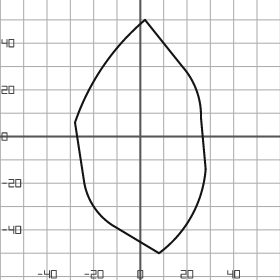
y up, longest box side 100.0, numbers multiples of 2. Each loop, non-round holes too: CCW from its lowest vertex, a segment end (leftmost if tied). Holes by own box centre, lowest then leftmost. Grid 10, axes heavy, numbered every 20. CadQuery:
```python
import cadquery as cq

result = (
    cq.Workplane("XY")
    .moveTo(8.0, -50.0)
    .threePointArc((22.0, -34.0), (28.0, -14.0))
    .lineTo(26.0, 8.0)
    .threePointArc((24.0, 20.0), (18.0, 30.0))
    .lineTo(2.0, 50.0)
    .threePointArc((-16.0, 30.0), (-28.0, 6.0))
    .lineTo(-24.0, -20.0)
    .threePointArc((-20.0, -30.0), (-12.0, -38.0))
    .close()
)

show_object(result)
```